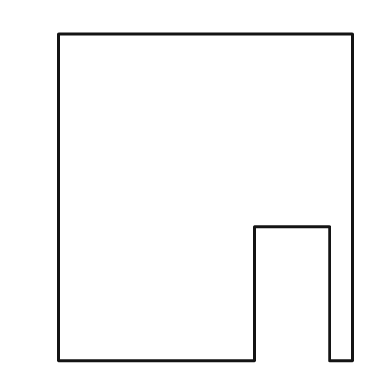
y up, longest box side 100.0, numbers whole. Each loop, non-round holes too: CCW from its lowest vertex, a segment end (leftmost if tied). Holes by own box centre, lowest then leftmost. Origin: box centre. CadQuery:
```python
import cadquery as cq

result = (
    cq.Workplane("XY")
    .moveTo(-45.0, -50.0)
    .lineTo(15.0, -50.0)
    .lineTo(15.0, -9.0)
    .lineTo(38.0, -9.0)
    .lineTo(38.0, -50.0)
    .lineTo(45.0, -50.0)
    .lineTo(45.0, 50.0)
    .lineTo(-45.0, 50.0)
    .close()
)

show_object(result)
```